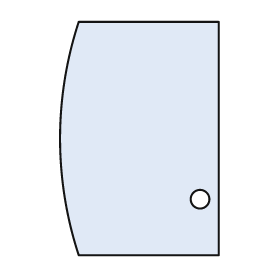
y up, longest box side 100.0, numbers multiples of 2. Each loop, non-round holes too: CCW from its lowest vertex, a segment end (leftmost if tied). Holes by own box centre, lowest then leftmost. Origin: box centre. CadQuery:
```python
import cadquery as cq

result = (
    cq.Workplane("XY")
    .moveTo(-26.0, -50.0)
    .lineTo(34.0, -50.0)
    .lineTo(34.0, 50.0)
    .lineTo(-26.0, 50.0)
    .threePointArc((-34.0, 0.0), (-26.0, -50.0))
    .close()
    .moveTo(26.0, -26.0)
    .circle(4.0)
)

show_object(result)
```